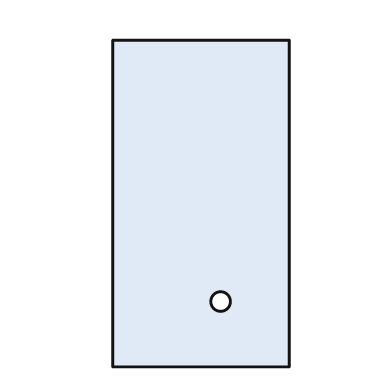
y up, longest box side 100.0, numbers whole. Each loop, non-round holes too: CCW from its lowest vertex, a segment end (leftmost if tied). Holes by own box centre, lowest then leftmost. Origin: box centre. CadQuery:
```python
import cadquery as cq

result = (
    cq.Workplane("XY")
    .moveTo(-27.0, -50.0)
    .lineTo(27.0, -50.0)
    .lineTo(27.0, 50.0)
    .lineTo(-27.0, 50.0)
    .close()
    .moveTo(6.0, -30.0)
    .circle(3.0)
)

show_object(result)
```